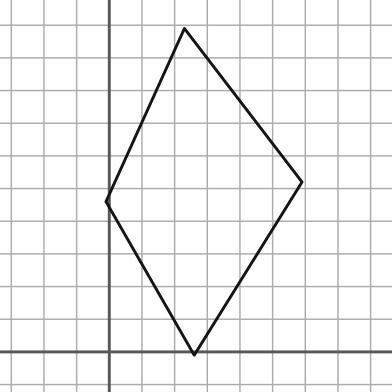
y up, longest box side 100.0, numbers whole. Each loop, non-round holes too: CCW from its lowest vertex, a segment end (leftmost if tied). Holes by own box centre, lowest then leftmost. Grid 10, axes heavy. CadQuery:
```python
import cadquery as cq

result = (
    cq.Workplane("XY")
    .moveTo(26.0, -1.0)
    .lineTo(59.0, 52.0)
    .lineTo(23.0, 99.0)
    .lineTo(-1.0, 46.0)
    .close()
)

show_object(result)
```